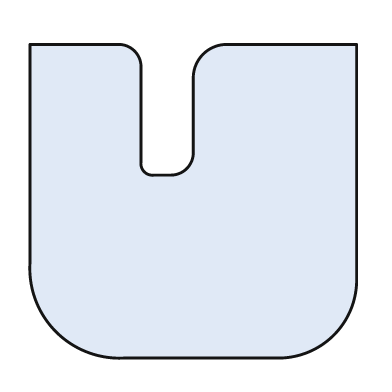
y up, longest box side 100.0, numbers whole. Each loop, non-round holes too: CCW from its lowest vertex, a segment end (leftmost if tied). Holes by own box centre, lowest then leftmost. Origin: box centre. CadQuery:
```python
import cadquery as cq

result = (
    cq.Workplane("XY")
    .moveTo(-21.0, -48.0)
    .lineTo(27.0, -48.0)
    .threePointArc((43.0, -41.0), (50.0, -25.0))
    .lineTo(50.0, 48.0)
    .lineTo(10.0, 48.0)
    .threePointArc((3.0, 45.0), (0.0, 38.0))
    .lineTo(0.0, 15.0)
    .threePointArc((-2.0, 10.0), (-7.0, 8.0))
    .lineTo(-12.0, 8.0)
    .threePointArc((-15.0, 9.0), (-16.0, 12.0))
    .lineTo(-16.0, 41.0)
    .threePointArc((-18.0, 46.0), (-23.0, 48.0))
    .lineTo(-50.0, 48.0)
    .lineTo(-50.0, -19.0)
    .threePointArc((-42.0, -40.0), (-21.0, -48.0))
    .close()
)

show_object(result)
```